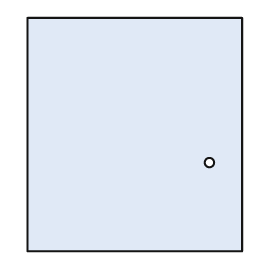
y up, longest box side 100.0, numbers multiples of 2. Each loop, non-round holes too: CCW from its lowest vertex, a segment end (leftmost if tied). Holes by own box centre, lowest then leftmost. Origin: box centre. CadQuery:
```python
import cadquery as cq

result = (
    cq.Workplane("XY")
    .moveTo(-46.0, -50.0)
    .lineTo(46.0, -50.0)
    .lineTo(46.0, 50.0)
    .lineTo(-46.0, 50.0)
    .close()
    .moveTo(32.0, -12.0)
    .circle(2.0)
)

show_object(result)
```